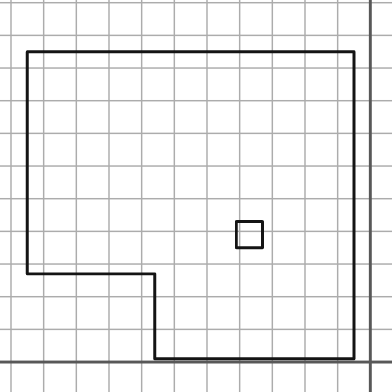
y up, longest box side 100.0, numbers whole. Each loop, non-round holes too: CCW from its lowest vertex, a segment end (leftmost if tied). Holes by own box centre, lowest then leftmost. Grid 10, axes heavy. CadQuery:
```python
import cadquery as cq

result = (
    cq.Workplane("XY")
    .moveTo(-66.0, 1.0)
    .lineTo(-5.0, 1.0)
    .lineTo(-5.0, 95.0)
    .lineTo(-105.0, 95.0)
    .lineTo(-105.0, 27.0)
    .lineTo(-66.0, 27.0)
    .close()
    .moveTo(-41.0, 35.0)
    .lineTo(-33.0, 35.0)
    .lineTo(-33.0, 43.0)
    .lineTo(-41.0, 43.0)
    .close()
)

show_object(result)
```